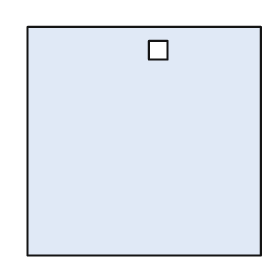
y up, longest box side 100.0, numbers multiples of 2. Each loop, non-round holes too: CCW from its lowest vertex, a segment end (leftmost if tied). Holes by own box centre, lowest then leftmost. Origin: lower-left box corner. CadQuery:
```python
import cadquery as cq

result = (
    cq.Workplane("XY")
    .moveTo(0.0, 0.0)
    .lineTo(100.0, 0.0)
    .lineTo(100.0, 98.0)
    .lineTo(0.0, 98.0)
    .close()
    .moveTo(52.0, 84.0)
    .lineTo(60.0, 84.0)
    .lineTo(60.0, 92.0)
    .lineTo(52.0, 92.0)
    .close()
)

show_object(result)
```